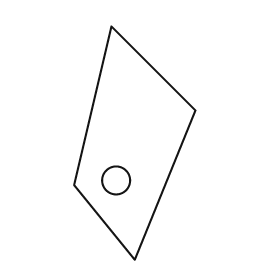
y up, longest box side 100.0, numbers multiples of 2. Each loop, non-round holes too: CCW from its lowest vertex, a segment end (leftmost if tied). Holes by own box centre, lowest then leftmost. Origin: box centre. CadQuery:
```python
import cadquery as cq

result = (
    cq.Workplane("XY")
    .moveTo(0.0, -50.0)
    .lineTo(26.0, 14.0)
    .lineTo(-10.0, 50.0)
    .lineTo(-26.0, -18.0)
    .close()
    .moveTo(-8.0, -16.0)
    .circle(6.0)
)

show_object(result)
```